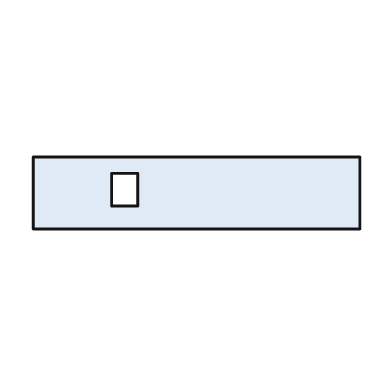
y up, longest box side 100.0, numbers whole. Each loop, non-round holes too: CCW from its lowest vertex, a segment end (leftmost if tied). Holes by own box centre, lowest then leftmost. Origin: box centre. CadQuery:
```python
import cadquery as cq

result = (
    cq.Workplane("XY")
    .moveTo(-50.0, -11.0)
    .lineTo(50.0, -11.0)
    .lineTo(50.0, 11.0)
    .lineTo(-50.0, 11.0)
    .close()
    .moveTo(-26.0, -4.0)
    .lineTo(-18.0, -4.0)
    .lineTo(-18.0, 6.0)
    .lineTo(-26.0, 6.0)
    .close()
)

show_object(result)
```